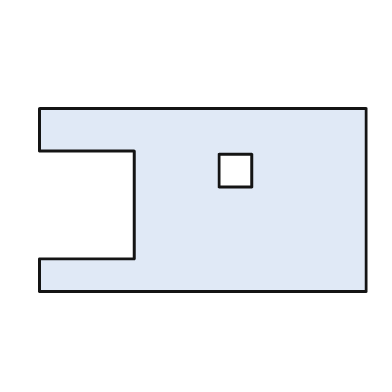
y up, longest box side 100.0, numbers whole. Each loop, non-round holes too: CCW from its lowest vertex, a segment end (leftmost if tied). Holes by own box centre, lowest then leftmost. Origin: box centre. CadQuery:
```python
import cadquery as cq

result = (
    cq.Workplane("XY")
    .moveTo(-50.0, -28.0)
    .lineTo(50.0, -28.0)
    .lineTo(50.0, 28.0)
    .lineTo(-50.0, 28.0)
    .lineTo(-50.0, 15.0)
    .lineTo(-21.0, 15.0)
    .lineTo(-21.0, -18.0)
    .lineTo(-50.0, -18.0)
    .close()
    .moveTo(5.0, 4.0)
    .lineTo(15.0, 4.0)
    .lineTo(15.0, 14.0)
    .lineTo(5.0, 14.0)
    .close()
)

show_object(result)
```